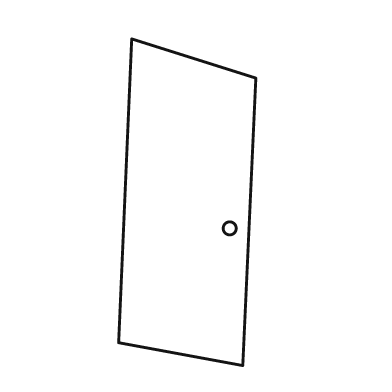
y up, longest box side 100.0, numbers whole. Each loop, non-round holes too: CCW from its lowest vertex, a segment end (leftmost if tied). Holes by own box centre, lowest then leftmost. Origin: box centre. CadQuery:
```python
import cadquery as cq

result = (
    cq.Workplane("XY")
    .moveTo(17.0, -50.0)
    .lineTo(21.0, 38.0)
    .lineTo(-17.0, 50.0)
    .lineTo(-21.0, -43.0)
    .close()
    .moveTo(13.0, -8.0)
    .circle(2.0)
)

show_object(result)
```